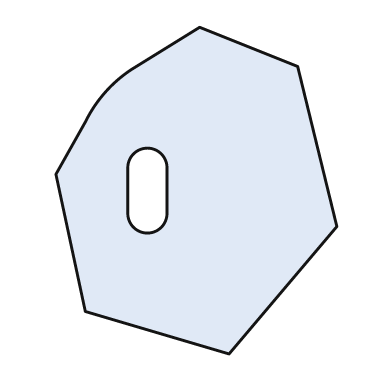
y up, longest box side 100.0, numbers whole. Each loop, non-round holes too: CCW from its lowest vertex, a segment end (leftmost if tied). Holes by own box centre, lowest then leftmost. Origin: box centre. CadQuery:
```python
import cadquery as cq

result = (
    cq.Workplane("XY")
    .moveTo(10.0, -50.0)
    .lineTo(43.0, -11.0)
    .lineTo(31.0, 38.0)
    .lineTo(1.0, 50.0)
    .lineTo(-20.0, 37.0)
    .threePointArc((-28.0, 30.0), (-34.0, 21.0))
    .lineTo(-43.0, 5.0)
    .lineTo(-34.0, -37.0)
    .close()
    .moveTo(-21.0, -7.0)
    .threePointArc((-15.0, -13.0), (-9.0, -7.0))
    .lineTo(-9.0, 7.0)
    .threePointArc((-15.0, 13.0), (-21.0, 7.0))
    .close()
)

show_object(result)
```